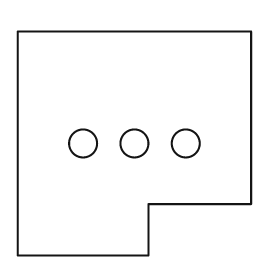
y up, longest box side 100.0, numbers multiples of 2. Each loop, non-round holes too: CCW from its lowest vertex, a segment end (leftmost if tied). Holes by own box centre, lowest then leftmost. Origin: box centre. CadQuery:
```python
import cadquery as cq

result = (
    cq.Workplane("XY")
    .moveTo(-50.0, -48.0)
    .lineTo(6.0, -48.0)
    .lineTo(6.0, -26.0)
    .lineTo(50.0, -26.0)
    .lineTo(50.0, 48.0)
    .lineTo(-50.0, 48.0)
    .close()
    .moveTo(-22.0, 0.0)
    .circle(6.0)
    .moveTo(0.0, 0.0)
    .circle(6.0)
    .moveTo(22.0, 0.0)
    .circle(6.0)
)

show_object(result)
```